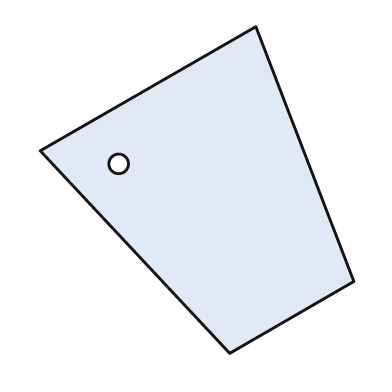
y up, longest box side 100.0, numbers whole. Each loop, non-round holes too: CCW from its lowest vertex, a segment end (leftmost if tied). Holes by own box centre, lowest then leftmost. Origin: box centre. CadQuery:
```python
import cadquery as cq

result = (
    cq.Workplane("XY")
    .moveTo(10.0, -50.0)
    .lineTo(48.0, -28.0)
    .lineTo(18.0, 50.0)
    .lineTo(-48.0, 12.0)
    .close()
    .moveTo(-24.0, 8.0)
    .circle(3.0)
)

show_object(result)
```